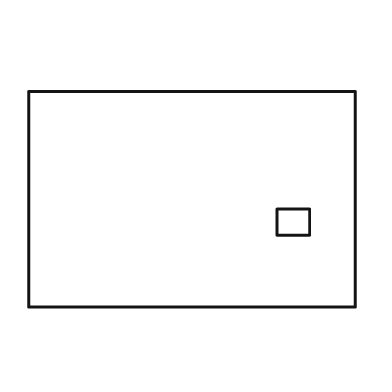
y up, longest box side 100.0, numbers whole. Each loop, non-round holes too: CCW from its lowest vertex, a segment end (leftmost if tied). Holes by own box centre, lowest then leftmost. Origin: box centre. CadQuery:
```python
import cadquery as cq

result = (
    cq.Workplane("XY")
    .moveTo(-50.0, -33.0)
    .lineTo(50.0, -33.0)
    .lineTo(50.0, 33.0)
    .lineTo(-50.0, 33.0)
    .close()
    .moveTo(26.0, -11.0)
    .lineTo(36.0, -11.0)
    .lineTo(36.0, -3.0)
    .lineTo(26.0, -3.0)
    .close()
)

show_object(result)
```